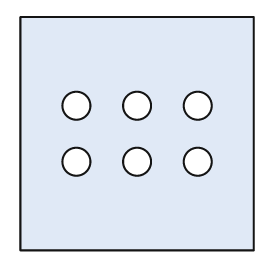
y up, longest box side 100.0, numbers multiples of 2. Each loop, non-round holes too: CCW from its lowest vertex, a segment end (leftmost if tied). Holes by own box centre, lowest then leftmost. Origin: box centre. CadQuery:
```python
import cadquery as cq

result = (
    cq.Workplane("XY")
    .moveTo(-50.0, -50.0)
    .lineTo(50.0, -50.0)
    .lineTo(50.0, 50.0)
    .lineTo(-50.0, 50.0)
    .close()
    .moveTo(-26.0, -12.0)
    .circle(6.0)
    .moveTo(0.0, -12.0)
    .circle(6.0)
    .moveTo(26.0, -12.0)
    .circle(6.0)
    .moveTo(-26.0, 12.0)
    .circle(6.0)
    .moveTo(0.0, 12.0)
    .circle(6.0)
    .moveTo(26.0, 12.0)
    .circle(6.0)
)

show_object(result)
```